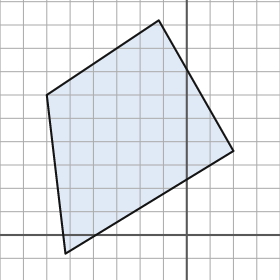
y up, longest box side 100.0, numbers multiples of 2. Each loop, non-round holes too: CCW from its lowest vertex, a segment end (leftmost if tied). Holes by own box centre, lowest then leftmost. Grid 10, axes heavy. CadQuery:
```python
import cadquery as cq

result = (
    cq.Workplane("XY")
    .moveTo(-52.0, -8.0)
    .lineTo(20.0, 36.0)
    .lineTo(-12.0, 92.0)
    .lineTo(-60.0, 60.0)
    .close()
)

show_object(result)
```